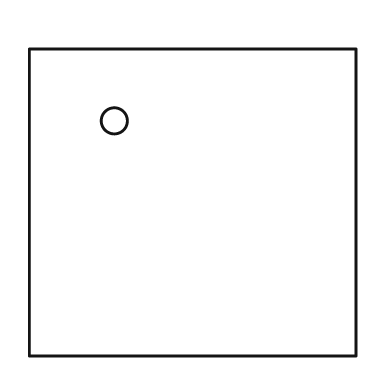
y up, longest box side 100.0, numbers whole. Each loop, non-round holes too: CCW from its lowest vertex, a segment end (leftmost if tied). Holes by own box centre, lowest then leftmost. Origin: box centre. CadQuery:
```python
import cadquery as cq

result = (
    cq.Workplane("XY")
    .moveTo(-50.0, -47.0)
    .lineTo(50.0, -47.0)
    .lineTo(50.0, 47.0)
    .lineTo(-50.0, 47.0)
    .close()
    .moveTo(-24.0, 25.0)
    .circle(4.0)
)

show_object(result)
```